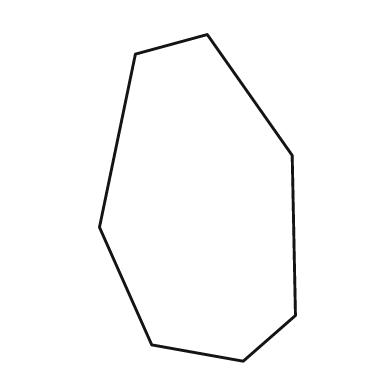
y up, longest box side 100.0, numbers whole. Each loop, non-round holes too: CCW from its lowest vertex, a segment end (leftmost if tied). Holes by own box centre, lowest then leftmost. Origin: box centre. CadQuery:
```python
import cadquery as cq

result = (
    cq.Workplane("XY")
    .moveTo(14.0, -50.0)
    .lineTo(30.0, -36.0)
    .lineTo(29.0, 13.0)
    .lineTo(3.0, 50.0)
    .lineTo(-19.0, 44.0)
    .lineTo(-30.0, -9.0)
    .lineTo(-14.0, -45.0)
    .close()
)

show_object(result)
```